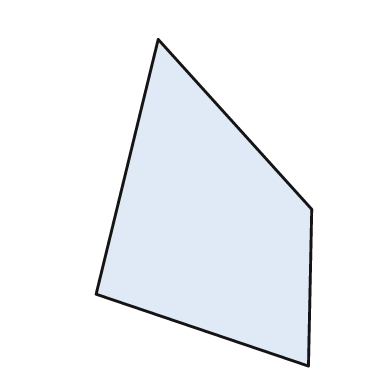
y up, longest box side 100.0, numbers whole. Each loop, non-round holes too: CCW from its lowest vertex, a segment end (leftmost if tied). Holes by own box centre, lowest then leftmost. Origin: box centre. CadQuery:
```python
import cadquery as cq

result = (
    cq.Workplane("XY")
    .moveTo(32.0, -50.0)
    .lineTo(33.0, -2.0)
    .lineTo(-14.0, 50.0)
    .lineTo(-33.0, -28.0)
    .close()
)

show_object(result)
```